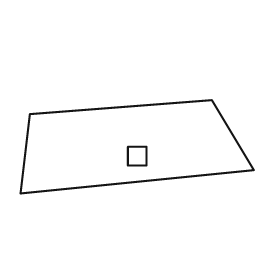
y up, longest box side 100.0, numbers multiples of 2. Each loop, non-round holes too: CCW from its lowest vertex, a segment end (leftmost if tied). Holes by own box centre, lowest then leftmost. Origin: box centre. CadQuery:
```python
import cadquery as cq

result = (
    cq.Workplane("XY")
    .moveTo(-50.0, -20.0)
    .lineTo(50.0, -10.0)
    .lineTo(32.0, 20.0)
    .lineTo(-46.0, 14.0)
    .close()
    .moveTo(-4.0, -8.0)
    .lineTo(4.0, -8.0)
    .lineTo(4.0, 0.0)
    .lineTo(-4.0, 0.0)
    .close()
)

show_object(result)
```